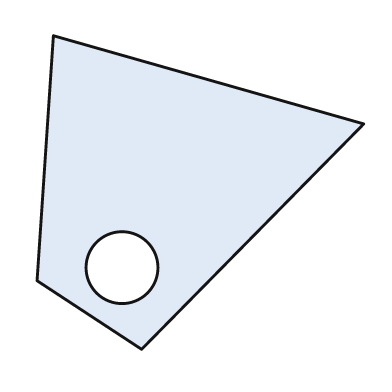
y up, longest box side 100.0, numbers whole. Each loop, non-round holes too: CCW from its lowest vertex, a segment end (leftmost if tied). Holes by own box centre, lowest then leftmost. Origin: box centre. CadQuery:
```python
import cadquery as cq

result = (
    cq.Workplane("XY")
    .moveTo(-18.0, -48.0)
    .lineTo(50.0, 21.0)
    .lineTo(-45.0, 48.0)
    .lineTo(-50.0, -27.0)
    .close()
    .moveTo(-24.0, -23.0)
    .circle(11.0)
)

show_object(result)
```